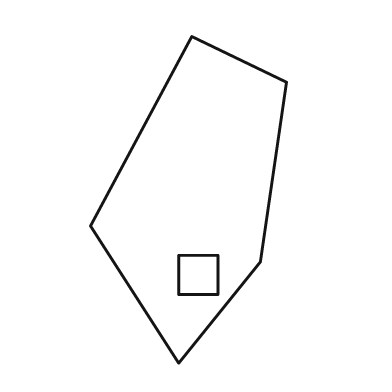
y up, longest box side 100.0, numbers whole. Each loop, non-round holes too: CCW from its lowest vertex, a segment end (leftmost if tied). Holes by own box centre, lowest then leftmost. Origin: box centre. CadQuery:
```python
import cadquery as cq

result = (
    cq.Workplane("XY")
    .moveTo(-3.0, -50.0)
    .lineTo(22.0, -19.0)
    .lineTo(30.0, 36.0)
    .lineTo(1.0, 50.0)
    .lineTo(-30.0, -8.0)
    .close()
    .moveTo(-3.0, -29.0)
    .lineTo(9.0, -29.0)
    .lineTo(9.0, -17.0)
    .lineTo(-3.0, -17.0)
    .close()
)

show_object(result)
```